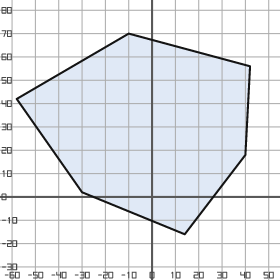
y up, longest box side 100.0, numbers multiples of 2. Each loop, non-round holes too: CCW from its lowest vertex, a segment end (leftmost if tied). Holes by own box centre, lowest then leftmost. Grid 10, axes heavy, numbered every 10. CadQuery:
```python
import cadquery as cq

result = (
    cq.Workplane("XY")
    .moveTo(14.0, -16.0)
    .lineTo(40.0, 18.0)
    .lineTo(42.0, 56.0)
    .lineTo(-10.0, 70.0)
    .lineTo(-58.0, 42.0)
    .lineTo(-30.0, 2.0)
    .close()
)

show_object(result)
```